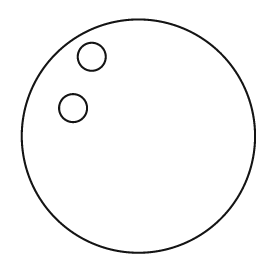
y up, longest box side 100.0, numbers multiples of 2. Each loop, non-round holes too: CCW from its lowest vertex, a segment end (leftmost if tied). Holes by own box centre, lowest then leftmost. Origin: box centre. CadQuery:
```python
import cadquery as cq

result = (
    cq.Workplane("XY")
    .moveTo(0.0, 0.0)
    .circle(50.0)
    .moveTo(-28.0, 12.0)
    .circle(6.0)
    .moveTo(-20.0, 34.0)
    .circle(6.0)
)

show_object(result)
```